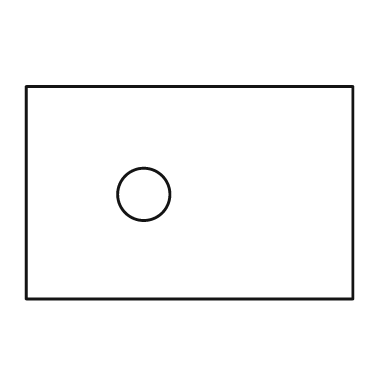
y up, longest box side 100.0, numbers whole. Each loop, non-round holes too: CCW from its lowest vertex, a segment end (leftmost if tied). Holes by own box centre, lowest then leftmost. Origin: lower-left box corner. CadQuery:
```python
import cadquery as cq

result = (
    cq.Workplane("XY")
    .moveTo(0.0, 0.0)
    .lineTo(100.0, 0.0)
    .lineTo(100.0, 65.0)
    .lineTo(0.0, 65.0)
    .close()
    .moveTo(36.0, 32.0)
    .circle(8.0)
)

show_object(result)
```